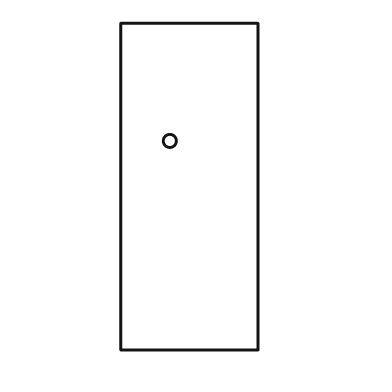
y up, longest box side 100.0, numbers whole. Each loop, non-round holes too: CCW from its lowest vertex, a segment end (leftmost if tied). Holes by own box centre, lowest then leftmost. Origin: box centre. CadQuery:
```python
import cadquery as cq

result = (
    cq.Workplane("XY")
    .moveTo(-21.0, -50.0)
    .lineTo(21.0, -50.0)
    .lineTo(21.0, 50.0)
    .lineTo(-21.0, 50.0)
    .close()
    .moveTo(-6.0, 14.0)
    .circle(2.0)
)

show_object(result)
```